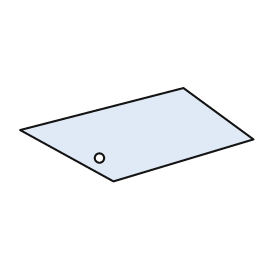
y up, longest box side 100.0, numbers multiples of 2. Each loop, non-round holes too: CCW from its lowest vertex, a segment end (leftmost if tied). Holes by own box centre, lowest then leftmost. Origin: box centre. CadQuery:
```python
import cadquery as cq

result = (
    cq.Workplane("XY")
    .moveTo(-10.0, -20.0)
    .lineTo(50.0, -2.0)
    .lineTo(20.0, 20.0)
    .lineTo(-50.0, 2.0)
    .close()
    .moveTo(-16.0, -10.0)
    .circle(2.0)
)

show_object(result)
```